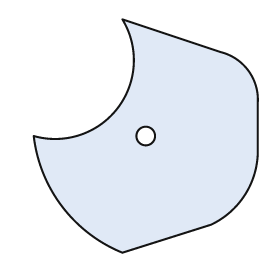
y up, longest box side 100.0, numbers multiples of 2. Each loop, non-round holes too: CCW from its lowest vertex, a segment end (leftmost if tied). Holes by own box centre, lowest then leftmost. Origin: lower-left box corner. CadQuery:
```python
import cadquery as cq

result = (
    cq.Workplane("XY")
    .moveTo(38.0, 0.0)
    .lineTo(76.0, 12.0)
    .threePointArc((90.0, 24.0), (96.0, 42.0))
    .lineTo(96.0, 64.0)
    .threePointArc((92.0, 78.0), (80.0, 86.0))
    .lineTo(38.0, 100.0)
    .threePointArc((36.0, 62.0), (0.0, 50.0))
    .threePointArc((12.0, 20.0), (38.0, 0.0))
    .close()
    .moveTo(48.0, 50.0)
    .circle(4.0)
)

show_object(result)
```